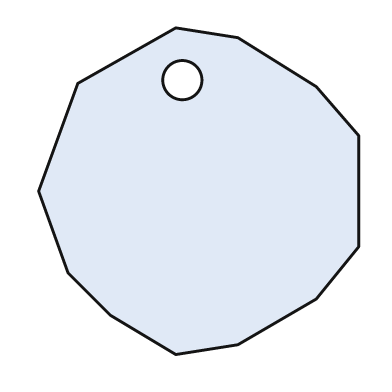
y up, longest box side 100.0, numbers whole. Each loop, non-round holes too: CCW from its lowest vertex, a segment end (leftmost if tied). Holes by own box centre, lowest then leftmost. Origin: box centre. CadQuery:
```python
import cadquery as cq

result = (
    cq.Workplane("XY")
    .moveTo(-7.0, -50.0)
    .lineTo(12.0, -47.0)
    .lineTo(36.0, -33.0)
    .lineTo(49.0, -17.0)
    .lineTo(49.0, 17.0)
    .lineTo(36.0, 32.0)
    .lineTo(12.0, 47.0)
    .lineTo(-7.0, 50.0)
    .lineTo(-37.0, 33.0)
    .lineTo(-49.0, 0.0)
    .lineTo(-40.0, -25.0)
    .lineTo(-27.0, -38.0)
    .close()
    .moveTo(-5.0, 34.0)
    .circle(6.0)
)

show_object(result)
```